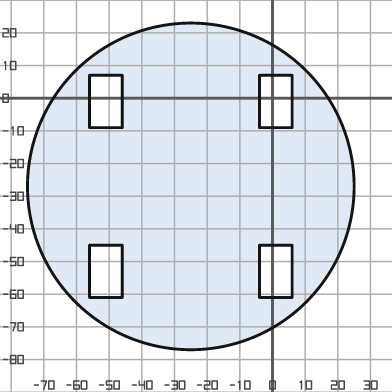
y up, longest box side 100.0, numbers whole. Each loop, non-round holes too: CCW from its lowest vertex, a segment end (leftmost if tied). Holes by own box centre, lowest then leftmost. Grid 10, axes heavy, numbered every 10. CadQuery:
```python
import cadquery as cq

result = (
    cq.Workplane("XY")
    .moveTo(-25.0, -27.0)
    .circle(50.0)
    .moveTo(-56.0, -61.0)
    .lineTo(-46.0, -61.0)
    .lineTo(-46.0, -45.0)
    .lineTo(-56.0, -45.0)
    .close()
    .moveTo(-4.0, -61.0)
    .lineTo(6.0, -61.0)
    .lineTo(6.0, -45.0)
    .lineTo(-4.0, -45.0)
    .close()
    .moveTo(-56.0, -9.0)
    .lineTo(-46.0, -9.0)
    .lineTo(-46.0, 7.0)
    .lineTo(-56.0, 7.0)
    .close()
    .moveTo(-4.0, -9.0)
    .lineTo(6.0, -9.0)
    .lineTo(6.0, 7.0)
    .lineTo(-4.0, 7.0)
    .close()
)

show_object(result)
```